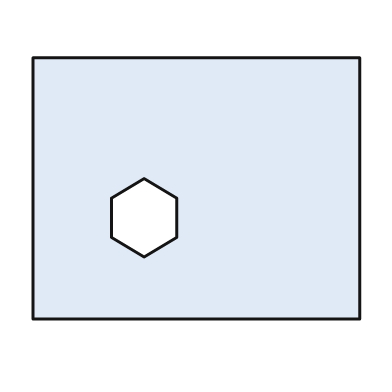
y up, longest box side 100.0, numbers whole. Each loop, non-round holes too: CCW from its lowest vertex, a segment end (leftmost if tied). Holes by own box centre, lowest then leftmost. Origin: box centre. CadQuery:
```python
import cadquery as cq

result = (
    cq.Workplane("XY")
    .moveTo(-50.0, -40.0)
    .lineTo(50.0, -40.0)
    .lineTo(50.0, 40.0)
    .lineTo(-50.0, 40.0)
    .close()
    .moveTo(-16.0, -21.0)
    .lineTo(-6.0, -15.0)
    .lineTo(-6.0, -3.0)
    .lineTo(-16.0, 3.0)
    .lineTo(-26.0, -3.0)
    .lineTo(-26.0, -15.0)
    .close()
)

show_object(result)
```